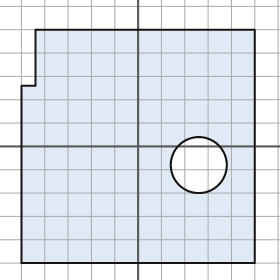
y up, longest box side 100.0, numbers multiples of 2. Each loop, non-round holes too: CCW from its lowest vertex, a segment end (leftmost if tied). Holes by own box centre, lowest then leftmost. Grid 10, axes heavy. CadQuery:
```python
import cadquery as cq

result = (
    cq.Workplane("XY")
    .moveTo(-50.0, -50.0)
    .lineTo(50.0, -50.0)
    .lineTo(50.0, 50.0)
    .lineTo(-44.0, 50.0)
    .lineTo(-44.0, 26.0)
    .lineTo(-50.0, 26.0)
    .close()
    .moveTo(26.0, -8.0)
    .circle(12.0)
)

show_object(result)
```